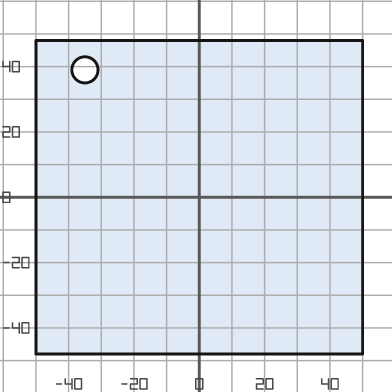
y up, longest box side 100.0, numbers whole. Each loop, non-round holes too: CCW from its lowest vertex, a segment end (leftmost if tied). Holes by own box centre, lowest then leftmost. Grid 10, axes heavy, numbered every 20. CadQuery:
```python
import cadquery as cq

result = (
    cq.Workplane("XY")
    .moveTo(-50.0, -48.0)
    .lineTo(50.0, -48.0)
    .lineTo(50.0, 48.0)
    .lineTo(-50.0, 48.0)
    .close()
    .moveTo(-35.0, 39.0)
    .circle(4.0)
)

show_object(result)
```